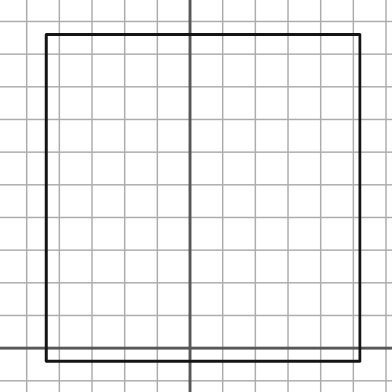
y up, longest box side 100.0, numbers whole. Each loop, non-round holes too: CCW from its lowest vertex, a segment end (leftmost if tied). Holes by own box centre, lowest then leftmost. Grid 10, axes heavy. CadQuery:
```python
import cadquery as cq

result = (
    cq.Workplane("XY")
    .moveTo(-44.0, -4.0)
    .lineTo(52.0, -4.0)
    .lineTo(52.0, 96.0)
    .lineTo(-44.0, 96.0)
    .close()
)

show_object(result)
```